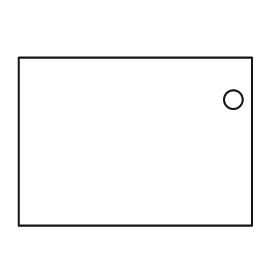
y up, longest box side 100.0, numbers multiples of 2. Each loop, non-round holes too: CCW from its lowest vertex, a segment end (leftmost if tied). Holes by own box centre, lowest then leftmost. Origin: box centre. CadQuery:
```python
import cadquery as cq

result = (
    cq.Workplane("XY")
    .moveTo(-50.0, -36.0)
    .lineTo(50.0, -36.0)
    .lineTo(50.0, 36.0)
    .lineTo(-50.0, 36.0)
    .close()
    .moveTo(42.0, 18.0)
    .circle(4.0)
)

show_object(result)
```